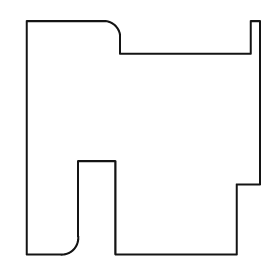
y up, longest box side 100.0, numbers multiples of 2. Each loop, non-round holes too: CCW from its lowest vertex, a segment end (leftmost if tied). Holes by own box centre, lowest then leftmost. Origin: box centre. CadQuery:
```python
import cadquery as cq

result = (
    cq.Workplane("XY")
    .moveTo(-50.0, -50.0)
    .lineTo(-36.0, -50.0)
    .threePointArc((-30.0, -48.0), (-28.0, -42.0))
    .lineTo(-28.0, -10.0)
    .lineTo(-12.0, -10.0)
    .lineTo(-12.0, -50.0)
    .lineTo(40.0, -50.0)
    .lineTo(40.0, -20.0)
    .lineTo(50.0, -20.0)
    .lineTo(50.0, 50.0)
    .lineTo(46.0, 50.0)
    .lineTo(46.0, 36.0)
    .lineTo(-10.0, 36.0)
    .lineTo(-10.0, 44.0)
    .threePointArc((-12.0, 48.0), (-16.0, 50.0))
    .lineTo(-50.0, 50.0)
    .close()
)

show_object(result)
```